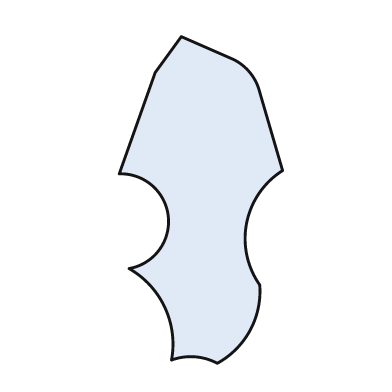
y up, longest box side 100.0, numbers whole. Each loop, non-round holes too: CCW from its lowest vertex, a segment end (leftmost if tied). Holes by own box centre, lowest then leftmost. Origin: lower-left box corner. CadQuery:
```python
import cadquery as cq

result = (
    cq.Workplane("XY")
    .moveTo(30.0, 0.0)
    .threePointArc((40.0, 10.0), (43.0, 24.0))
    .threePointArc((39.0, 43.0), (50.0, 59.0))
    .lineTo(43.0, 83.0)
    .threePointArc((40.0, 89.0), (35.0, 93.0))
    .lineTo(19.0, 100.0)
    .lineTo(11.0, 89.0)
    .lineTo(0.0, 58.0)
    .threePointArc((15.0, 45.0), (3.0, 29.0))
    .threePointArc((14.0, 17.0), (16.0, 1.0))
    .threePointArc((23.0, 2.0), (30.0, 0.0))
    .close()
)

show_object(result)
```